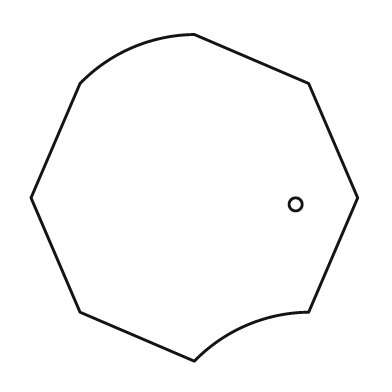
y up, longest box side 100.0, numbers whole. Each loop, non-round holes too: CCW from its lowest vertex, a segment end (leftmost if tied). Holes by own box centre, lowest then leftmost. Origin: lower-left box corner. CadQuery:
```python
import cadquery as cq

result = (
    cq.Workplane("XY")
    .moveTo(50.0, 0.0)
    .threePointArc((66.0, 11.0), (85.0, 15.0))
    .lineTo(100.0, 50.0)
    .lineTo(85.0, 85.0)
    .lineTo(50.0, 100.0)
    .threePointArc((31.0, 96.0), (15.0, 85.0))
    .lineTo(0.0, 50.0)
    .lineTo(15.0, 15.0)
    .close()
    .moveTo(81.0, 48.0)
    .circle(2.0)
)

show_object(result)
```